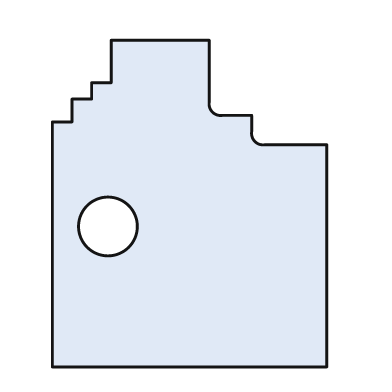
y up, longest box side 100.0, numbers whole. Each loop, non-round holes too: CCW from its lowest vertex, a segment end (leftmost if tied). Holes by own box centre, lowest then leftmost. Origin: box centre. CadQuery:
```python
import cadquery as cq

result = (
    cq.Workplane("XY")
    .moveTo(-42.0, -50.0)
    .lineTo(42.0, -50.0)
    .lineTo(42.0, 18.0)
    .lineTo(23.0, 18.0)
    .threePointArc((20.0, 19.0), (19.0, 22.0))
    .lineTo(19.0, 27.0)
    .lineTo(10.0, 27.0)
    .threePointArc((7.0, 28.0), (6.0, 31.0))
    .lineTo(6.0, 50.0)
    .lineTo(-24.0, 50.0)
    .lineTo(-24.0, 37.0)
    .lineTo(-30.0, 37.0)
    .lineTo(-30.0, 32.0)
    .lineTo(-36.0, 32.0)
    .lineTo(-36.0, 25.0)
    .lineTo(-42.0, 25.0)
    .close()
    .moveTo(-25.0, -7.0)
    .circle(9.0)
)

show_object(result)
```